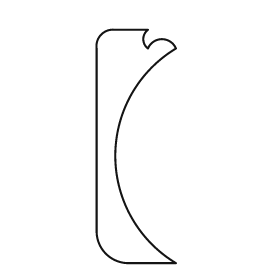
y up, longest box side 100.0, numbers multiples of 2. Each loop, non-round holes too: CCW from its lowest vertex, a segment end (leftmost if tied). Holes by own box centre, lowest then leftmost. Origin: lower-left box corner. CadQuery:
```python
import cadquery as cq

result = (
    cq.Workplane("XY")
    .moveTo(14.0, 0.0)
    .lineTo(34.0, 0.0)
    .threePointArc((8.0, 46.0), (34.0, 92.0))
    .threePointArc((28.0, 96.0), (22.0, 92.0))
    .threePointArc((20.0, 96.0), (22.0, 100.0))
    .lineTo(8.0, 100.0)
    .threePointArc((2.0, 98.0), (0.0, 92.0))
    .lineTo(0.0, 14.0)
    .threePointArc((4.0, 4.0), (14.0, 0.0))
    .close()
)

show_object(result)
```